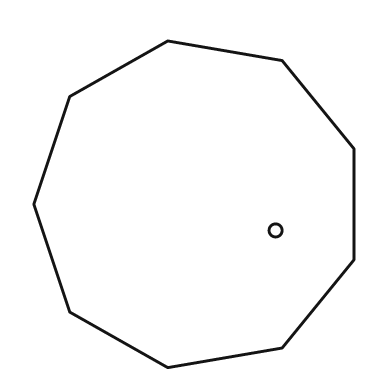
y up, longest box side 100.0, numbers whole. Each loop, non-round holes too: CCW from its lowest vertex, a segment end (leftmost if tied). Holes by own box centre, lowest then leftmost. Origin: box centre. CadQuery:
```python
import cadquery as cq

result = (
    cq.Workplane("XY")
    .moveTo(-8.0, -50.0)
    .lineTo(27.0, -44.0)
    .lineTo(49.0, -17.0)
    .lineTo(49.0, 17.0)
    .lineTo(27.0, 44.0)
    .lineTo(-8.0, 50.0)
    .lineTo(-38.0, 33.0)
    .lineTo(-49.0, 0.0)
    .lineTo(-38.0, -33.0)
    .close()
    .moveTo(25.0, -8.0)
    .circle(2.0)
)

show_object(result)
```